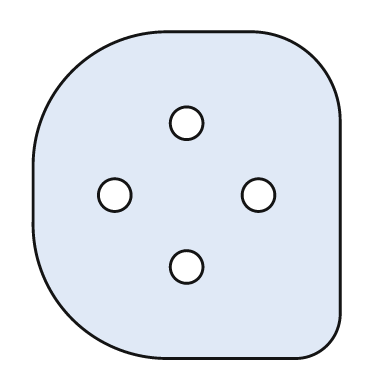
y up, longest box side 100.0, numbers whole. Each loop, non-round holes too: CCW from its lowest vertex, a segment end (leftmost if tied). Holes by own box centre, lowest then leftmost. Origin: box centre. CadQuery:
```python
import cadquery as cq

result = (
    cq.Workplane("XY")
    .moveTo(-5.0, -50.0)
    .lineTo(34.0, -50.0)
    .threePointArc((43.0, -46.0), (47.0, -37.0))
    .lineTo(47.0, 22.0)
    .threePointArc((39.0, 42.0), (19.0, 50.0))
    .lineTo(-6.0, 50.0)
    .threePointArc((-35.0, 38.0), (-47.0, 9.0))
    .lineTo(-47.0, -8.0)
    .threePointArc((-35.0, -38.0), (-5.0, -50.0))
    .close()
    .moveTo(0.0, -22.0)
    .circle(5.0)
    .moveTo(-22.0, 0.0)
    .circle(5.0)
    .moveTo(22.0, 0.0)
    .circle(5.0)
    .moveTo(0.0, 22.0)
    .circle(5.0)
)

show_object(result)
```